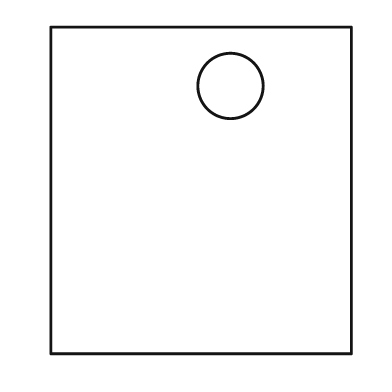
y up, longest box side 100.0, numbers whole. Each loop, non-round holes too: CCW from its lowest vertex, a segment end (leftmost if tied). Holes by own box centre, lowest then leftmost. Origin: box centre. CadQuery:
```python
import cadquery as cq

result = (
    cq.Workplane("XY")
    .moveTo(-46.0, -50.0)
    .lineTo(46.0, -50.0)
    .lineTo(46.0, 50.0)
    .lineTo(-46.0, 50.0)
    .close()
    .moveTo(9.0, 32.0)
    .circle(10.0)
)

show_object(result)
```